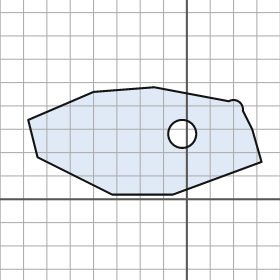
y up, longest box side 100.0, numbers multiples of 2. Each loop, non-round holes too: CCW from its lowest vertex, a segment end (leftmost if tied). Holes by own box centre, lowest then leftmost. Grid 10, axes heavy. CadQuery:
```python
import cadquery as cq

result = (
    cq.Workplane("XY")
    .moveTo(-32.0, 2.0)
    .lineTo(-6.0, 2.0)
    .lineTo(32.0, 16.0)
    .lineTo(28.0, 30.0)
    .lineTo(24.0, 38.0)
    .threePointArc((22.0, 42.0), (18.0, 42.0))
    .lineTo(-14.0, 48.0)
    .lineTo(-40.0, 46.0)
    .lineTo(-68.0, 34.0)
    .lineTo(-64.0, 18.0)
    .close()
    .moveTo(-2.0, 28.0)
    .circle(6.0)
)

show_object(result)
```